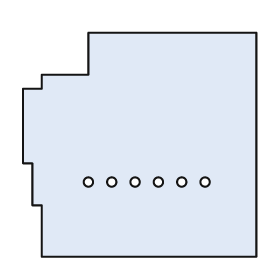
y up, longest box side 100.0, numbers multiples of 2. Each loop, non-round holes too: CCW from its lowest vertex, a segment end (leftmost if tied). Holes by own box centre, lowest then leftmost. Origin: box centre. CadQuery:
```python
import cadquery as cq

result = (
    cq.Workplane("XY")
    .moveTo(-42.0, -48.0)
    .lineTo(50.0, -48.0)
    .lineTo(50.0, 48.0)
    .lineTo(-22.0, 48.0)
    .lineTo(-22.0, 30.0)
    .lineTo(-42.0, 30.0)
    .lineTo(-42.0, 24.0)
    .lineTo(-50.0, 24.0)
    .lineTo(-50.0, -8.0)
    .lineTo(-46.0, -8.0)
    .lineTo(-46.0, -26.0)
    .lineTo(-42.0, -26.0)
    .close()
    .moveTo(-22.0, -16.0)
    .circle(2.0)
    .moveTo(-12.0, -16.0)
    .circle(2.0)
    .moveTo(-2.0, -16.0)
    .circle(2.0)
    .moveTo(8.0, -16.0)
    .circle(2.0)
    .moveTo(18.0, -16.0)
    .circle(2.0)
    .moveTo(28.0, -16.0)
    .circle(2.0)
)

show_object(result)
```